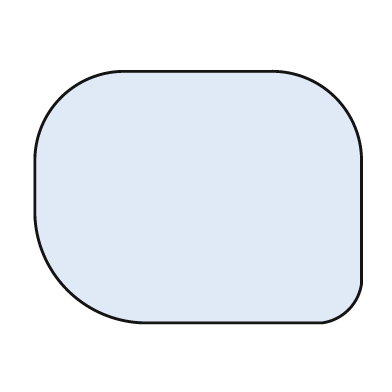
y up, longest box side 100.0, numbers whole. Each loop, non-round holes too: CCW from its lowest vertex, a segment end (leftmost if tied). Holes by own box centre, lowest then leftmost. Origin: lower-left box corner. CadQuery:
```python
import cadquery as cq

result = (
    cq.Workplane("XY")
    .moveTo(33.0, 0.0)
    .lineTo(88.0, 0.0)
    .threePointArc((96.0, 4.0), (100.0, 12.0))
    .lineTo(100.0, 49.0)
    .threePointArc((92.0, 69.0), (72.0, 77.0))
    .lineTo(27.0, 77.0)
    .threePointArc((8.0, 69.0), (0.0, 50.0))
    .lineTo(0.0, 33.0)
    .threePointArc((10.0, 10.0), (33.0, 0.0))
    .close()
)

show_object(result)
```